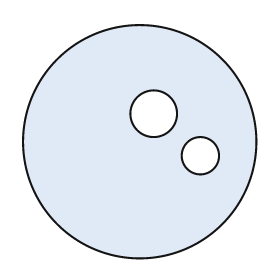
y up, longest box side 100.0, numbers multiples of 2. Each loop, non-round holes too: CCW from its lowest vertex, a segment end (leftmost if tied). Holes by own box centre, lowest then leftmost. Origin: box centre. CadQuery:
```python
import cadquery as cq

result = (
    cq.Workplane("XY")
    .moveTo(0.0, 0.0)
    .circle(50.0)
    .moveTo(26.0, -6.0)
    .circle(8.0)
    .moveTo(6.0, 12.0)
    .circle(10.0)
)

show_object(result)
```